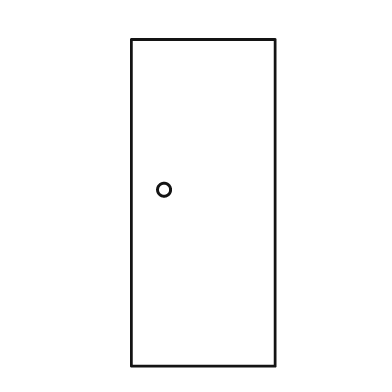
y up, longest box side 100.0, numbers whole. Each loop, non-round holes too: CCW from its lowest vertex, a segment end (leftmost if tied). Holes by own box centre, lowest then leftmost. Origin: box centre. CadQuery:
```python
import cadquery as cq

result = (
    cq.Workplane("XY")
    .moveTo(-22.0, -50.0)
    .lineTo(22.0, -50.0)
    .lineTo(22.0, 50.0)
    .lineTo(-22.0, 50.0)
    .close()
    .moveTo(-12.0, 4.0)
    .circle(2.0)
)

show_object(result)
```